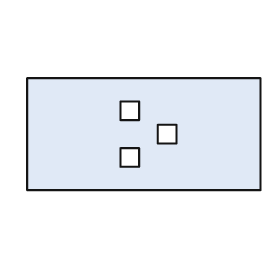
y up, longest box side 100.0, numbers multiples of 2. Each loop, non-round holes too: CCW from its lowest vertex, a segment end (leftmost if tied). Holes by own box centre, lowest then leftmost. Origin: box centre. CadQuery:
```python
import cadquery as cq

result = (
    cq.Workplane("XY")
    .moveTo(-50.0, -24.0)
    .lineTo(50.0, -24.0)
    .lineTo(50.0, 24.0)
    .lineTo(-50.0, 24.0)
    .close()
    .moveTo(-10.0, -14.0)
    .lineTo(-2.0, -14.0)
    .lineTo(-2.0, -6.0)
    .lineTo(-10.0, -6.0)
    .close()
    .moveTo(6.0, -4.0)
    .lineTo(14.0, -4.0)
    .lineTo(14.0, 4.0)
    .lineTo(6.0, 4.0)
    .close()
    .moveTo(-10.0, 6.0)
    .lineTo(-2.0, 6.0)
    .lineTo(-2.0, 14.0)
    .lineTo(-10.0, 14.0)
    .close()
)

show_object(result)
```